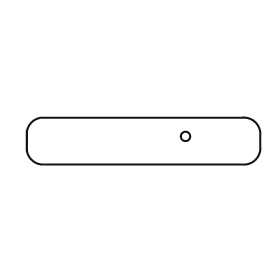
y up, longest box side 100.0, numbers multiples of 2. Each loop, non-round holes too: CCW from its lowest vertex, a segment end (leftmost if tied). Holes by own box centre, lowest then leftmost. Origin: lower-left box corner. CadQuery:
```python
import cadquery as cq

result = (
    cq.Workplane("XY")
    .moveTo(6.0, 0.0)
    .lineTo(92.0, 0.0)
    .threePointArc((98.0, 2.0), (100.0, 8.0))
    .lineTo(100.0, 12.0)
    .threePointArc((98.0, 18.0), (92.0, 20.0))
    .lineTo(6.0, 20.0)
    .threePointArc((2.0, 18.0), (0.0, 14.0))
    .lineTo(0.0, 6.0)
    .threePointArc((2.0, 2.0), (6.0, 0.0))
    .close()
    .moveTo(68.0, 12.0)
    .circle(2.0)
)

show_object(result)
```